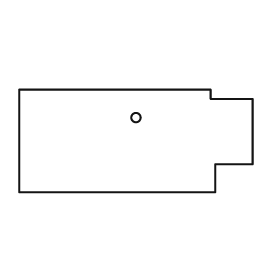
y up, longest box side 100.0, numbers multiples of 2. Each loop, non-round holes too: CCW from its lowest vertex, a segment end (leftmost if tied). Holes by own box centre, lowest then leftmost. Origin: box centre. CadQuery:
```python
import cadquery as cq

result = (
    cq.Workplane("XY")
    .moveTo(-50.0, -22.0)
    .lineTo(34.0, -22.0)
    .lineTo(34.0, -10.0)
    .lineTo(50.0, -10.0)
    .lineTo(50.0, 18.0)
    .lineTo(32.0, 18.0)
    .lineTo(32.0, 22.0)
    .lineTo(-50.0, 22.0)
    .close()
    .moveTo(0.0, 10.0)
    .circle(2.0)
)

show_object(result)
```